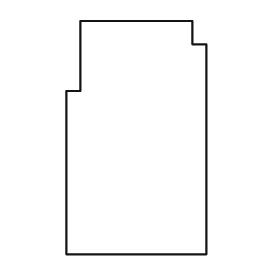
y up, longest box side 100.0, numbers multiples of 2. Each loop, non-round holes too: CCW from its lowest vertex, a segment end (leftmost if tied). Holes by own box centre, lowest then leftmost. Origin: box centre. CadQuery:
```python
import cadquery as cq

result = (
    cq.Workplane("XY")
    .moveTo(-30.0, -50.0)
    .lineTo(30.0, -50.0)
    .lineTo(30.0, 40.0)
    .lineTo(24.0, 40.0)
    .lineTo(24.0, 50.0)
    .lineTo(-24.0, 50.0)
    .lineTo(-24.0, 20.0)
    .lineTo(-30.0, 20.0)
    .close()
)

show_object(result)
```